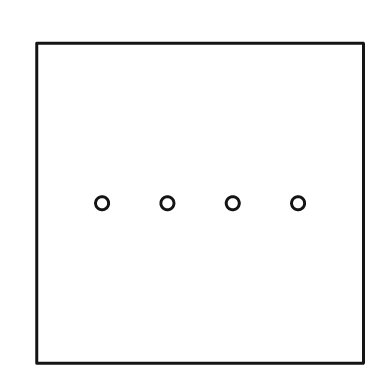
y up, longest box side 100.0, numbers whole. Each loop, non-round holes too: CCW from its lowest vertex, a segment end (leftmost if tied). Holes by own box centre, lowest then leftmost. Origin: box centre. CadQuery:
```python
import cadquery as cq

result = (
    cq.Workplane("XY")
    .moveTo(-50.0, -49.0)
    .lineTo(50.0, -49.0)
    .lineTo(50.0, 49.0)
    .lineTo(-50.0, 49.0)
    .close()
    .moveTo(-30.0, 0.0)
    .circle(2.0)
    .moveTo(-10.0, 0.0)
    .circle(2.0)
    .moveTo(10.0, 0.0)
    .circle(2.0)
    .moveTo(30.0, 0.0)
    .circle(2.0)
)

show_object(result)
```